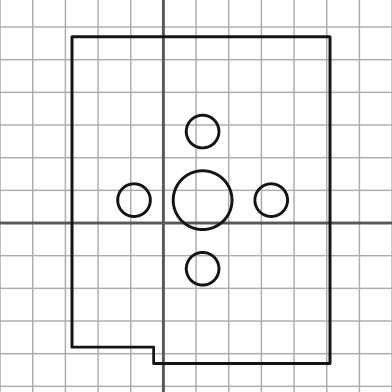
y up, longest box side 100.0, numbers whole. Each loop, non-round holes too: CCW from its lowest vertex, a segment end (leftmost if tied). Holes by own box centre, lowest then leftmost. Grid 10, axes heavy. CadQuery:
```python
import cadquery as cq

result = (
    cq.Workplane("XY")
    .moveTo(-3.0, -43.0)
    .lineTo(51.0, -43.0)
    .lineTo(51.0, 57.0)
    .lineTo(-28.0, 57.0)
    .lineTo(-28.0, -38.0)
    .lineTo(-3.0, -38.0)
    .close()
    .moveTo(12.0, -14.0)
    .circle(5.0)
    .moveTo(-9.0, 7.0)
    .circle(5.0)
    .moveTo(12.0, 7.0)
    .circle(9.0)
    .moveTo(33.0, 7.0)
    .circle(5.0)
    .moveTo(12.0, 28.0)
    .circle(5.0)
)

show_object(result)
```